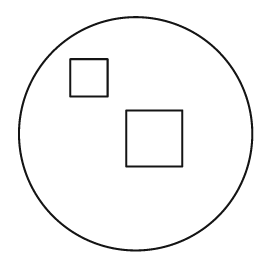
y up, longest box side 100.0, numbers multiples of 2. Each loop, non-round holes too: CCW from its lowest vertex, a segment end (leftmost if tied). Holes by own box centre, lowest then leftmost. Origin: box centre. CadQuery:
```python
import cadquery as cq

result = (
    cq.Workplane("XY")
    .moveTo(0.0, 0.0)
    .circle(50.0)
    .moveTo(-4.0, -14.0)
    .lineTo(20.0, -14.0)
    .lineTo(20.0, 10.0)
    .lineTo(-4.0, 10.0)
    .close()
    .moveTo(-28.0, 16.0)
    .lineTo(-12.0, 16.0)
    .lineTo(-12.0, 32.0)
    .lineTo(-28.0, 32.0)
    .close()
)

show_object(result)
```